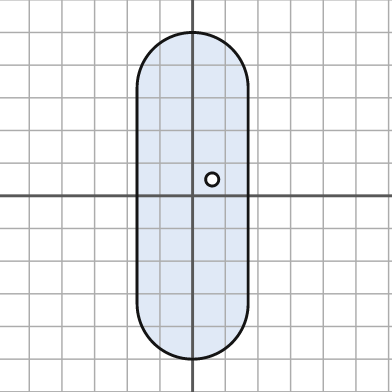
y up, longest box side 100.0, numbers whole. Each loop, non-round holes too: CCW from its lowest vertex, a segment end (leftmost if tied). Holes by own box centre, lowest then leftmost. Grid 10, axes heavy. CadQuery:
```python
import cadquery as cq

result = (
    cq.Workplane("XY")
    .moveTo(-17.0, -33.0)
    .threePointArc((0.0, -50.0), (17.0, -33.0))
    .lineTo(17.0, 33.0)
    .threePointArc((0.0, 50.0), (-17.0, 33.0))
    .close()
    .moveTo(6.0, 5.0)
    .circle(2.0)
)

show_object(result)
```